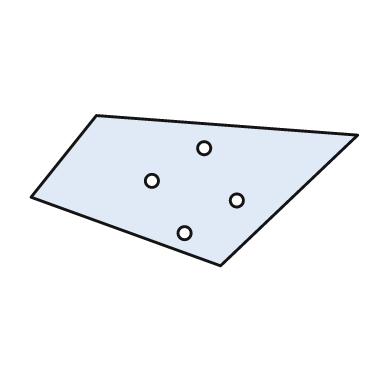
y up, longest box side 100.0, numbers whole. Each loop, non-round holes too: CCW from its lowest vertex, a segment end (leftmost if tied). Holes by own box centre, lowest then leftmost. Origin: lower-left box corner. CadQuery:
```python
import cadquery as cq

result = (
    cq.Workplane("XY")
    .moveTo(58.0, 0.0)
    .lineTo(100.0, 40.0)
    .lineTo(20.0, 46.0)
    .lineTo(0.0, 21.0)
    .close()
    .moveTo(47.0, 10.0)
    .circle(2.0)
    .moveTo(63.0, 20.0)
    .circle(2.0)
    .moveTo(37.0, 26.0)
    .circle(2.0)
    .moveTo(53.0, 36.0)
    .circle(2.0)
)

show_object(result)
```